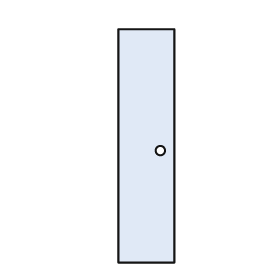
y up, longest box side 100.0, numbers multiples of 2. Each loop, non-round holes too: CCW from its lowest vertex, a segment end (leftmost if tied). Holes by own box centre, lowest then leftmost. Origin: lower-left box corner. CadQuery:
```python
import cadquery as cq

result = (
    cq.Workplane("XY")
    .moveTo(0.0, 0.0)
    .lineTo(24.0, 0.0)
    .lineTo(24.0, 100.0)
    .lineTo(0.0, 100.0)
    .close()
    .moveTo(18.0, 48.0)
    .circle(2.0)
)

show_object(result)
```